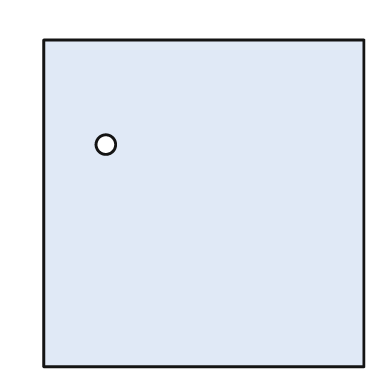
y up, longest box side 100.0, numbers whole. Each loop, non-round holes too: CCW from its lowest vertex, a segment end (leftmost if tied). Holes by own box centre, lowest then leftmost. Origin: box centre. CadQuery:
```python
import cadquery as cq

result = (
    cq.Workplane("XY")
    .moveTo(-49.0, -50.0)
    .lineTo(49.0, -50.0)
    .lineTo(49.0, 50.0)
    .lineTo(-49.0, 50.0)
    .close()
    .moveTo(-30.0, 18.0)
    .circle(3.0)
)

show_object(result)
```